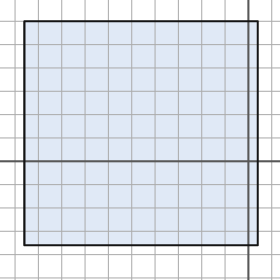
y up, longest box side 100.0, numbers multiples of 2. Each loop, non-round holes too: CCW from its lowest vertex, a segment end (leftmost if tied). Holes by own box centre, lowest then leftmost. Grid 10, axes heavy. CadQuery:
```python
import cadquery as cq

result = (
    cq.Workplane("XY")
    .moveTo(-96.0, -36.0)
    .lineTo(4.0, -36.0)
    .lineTo(4.0, 60.0)
    .lineTo(-96.0, 60.0)
    .close()
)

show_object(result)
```